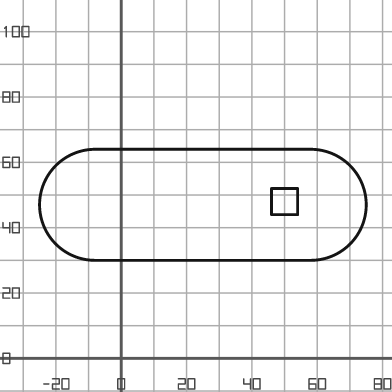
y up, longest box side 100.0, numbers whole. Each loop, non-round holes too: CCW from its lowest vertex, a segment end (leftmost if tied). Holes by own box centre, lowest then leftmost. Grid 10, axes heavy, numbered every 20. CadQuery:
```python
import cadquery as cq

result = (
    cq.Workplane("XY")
    .moveTo(-8.0, 30.0)
    .lineTo(58.0, 30.0)
    .threePointArc((75.0, 47.0), (58.0, 64.0))
    .lineTo(-8.0, 64.0)
    .threePointArc((-25.0, 47.0), (-8.0, 30.0))
    .close()
    .moveTo(46.0, 44.0)
    .lineTo(54.0, 44.0)
    .lineTo(54.0, 52.0)
    .lineTo(46.0, 52.0)
    .close()
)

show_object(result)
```